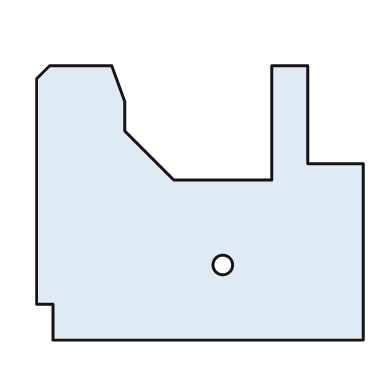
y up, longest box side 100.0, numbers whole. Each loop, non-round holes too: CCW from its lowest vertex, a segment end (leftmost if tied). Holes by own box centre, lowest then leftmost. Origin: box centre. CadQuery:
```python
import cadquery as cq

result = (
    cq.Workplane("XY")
    .moveTo(-45.0, -42.0)
    .lineTo(50.0, -42.0)
    .lineTo(50.0, 12.0)
    .lineTo(33.0, 12.0)
    .lineTo(33.0, 42.0)
    .lineTo(22.0, 42.0)
    .lineTo(22.0, 7.0)
    .lineTo(-8.0, 7.0)
    .lineTo(-23.0, 22.0)
    .lineTo(-23.0, 31.0)
    .lineTo(-27.0, 42.0)
    .lineTo(-46.0, 42.0)
    .lineTo(-50.0, 38.0)
    .lineTo(-50.0, -31.0)
    .lineTo(-45.0, -31.0)
    .close()
    .moveTo(7.0, -19.0)
    .circle(3.0)
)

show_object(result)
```